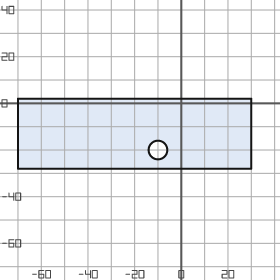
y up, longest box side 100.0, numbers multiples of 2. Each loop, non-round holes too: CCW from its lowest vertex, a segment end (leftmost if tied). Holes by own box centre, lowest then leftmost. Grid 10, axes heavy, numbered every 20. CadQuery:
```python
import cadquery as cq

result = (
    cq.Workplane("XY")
    .moveTo(-70.0, -28.0)
    .lineTo(30.0, -28.0)
    .lineTo(30.0, 2.0)
    .lineTo(-70.0, 2.0)
    .close()
    .moveTo(-10.0, -20.0)
    .circle(4.0)
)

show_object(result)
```